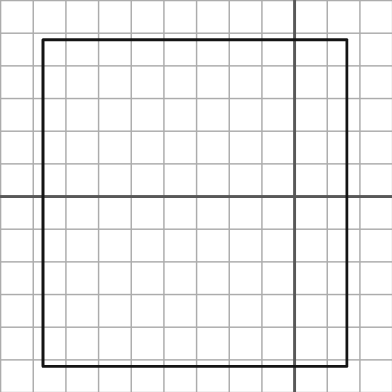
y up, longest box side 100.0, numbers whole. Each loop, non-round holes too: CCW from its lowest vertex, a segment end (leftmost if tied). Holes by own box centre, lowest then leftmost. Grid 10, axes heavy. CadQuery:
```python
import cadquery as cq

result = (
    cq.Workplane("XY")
    .moveTo(-77.0, -52.0)
    .lineTo(16.0, -52.0)
    .lineTo(16.0, 48.0)
    .lineTo(-77.0, 48.0)
    .close()
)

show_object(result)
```